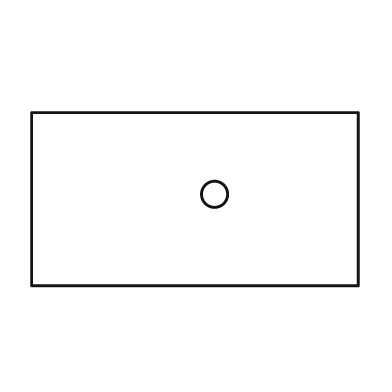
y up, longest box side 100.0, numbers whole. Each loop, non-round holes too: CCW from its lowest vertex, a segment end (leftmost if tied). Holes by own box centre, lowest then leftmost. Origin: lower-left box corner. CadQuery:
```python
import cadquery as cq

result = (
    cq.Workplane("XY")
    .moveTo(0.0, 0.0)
    .lineTo(100.0, 0.0)
    .lineTo(100.0, 53.0)
    .lineTo(0.0, 53.0)
    .close()
    .moveTo(56.0, 28.0)
    .circle(4.0)
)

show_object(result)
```